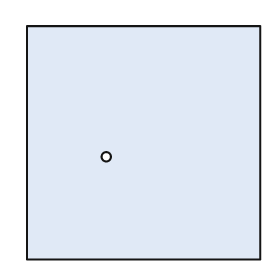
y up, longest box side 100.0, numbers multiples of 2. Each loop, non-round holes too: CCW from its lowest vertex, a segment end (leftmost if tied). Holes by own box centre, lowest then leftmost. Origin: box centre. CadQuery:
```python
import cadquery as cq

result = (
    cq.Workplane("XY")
    .moveTo(-50.0, -50.0)
    .lineTo(50.0, -50.0)
    .lineTo(50.0, 50.0)
    .lineTo(-50.0, 50.0)
    .close()
    .moveTo(-16.0, -6.0)
    .circle(2.0)
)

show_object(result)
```